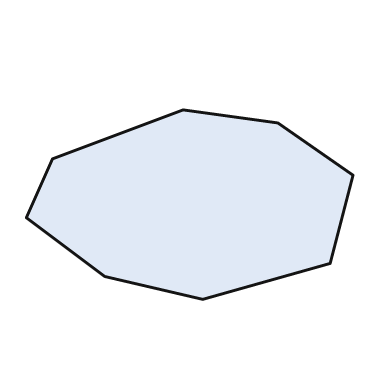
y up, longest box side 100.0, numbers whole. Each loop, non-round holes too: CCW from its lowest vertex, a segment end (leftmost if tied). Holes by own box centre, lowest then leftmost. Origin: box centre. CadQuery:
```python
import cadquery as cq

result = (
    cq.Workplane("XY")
    .moveTo(4.0, -29.0)
    .lineTo(43.0, -18.0)
    .lineTo(50.0, 9.0)
    .lineTo(27.0, 25.0)
    .lineTo(-2.0, 29.0)
    .lineTo(-42.0, 14.0)
    .lineTo(-50.0, -4.0)
    .lineTo(-26.0, -22.0)
    .close()
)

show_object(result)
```